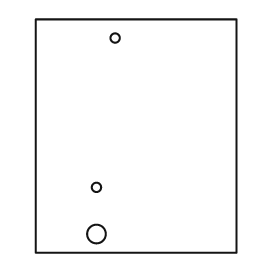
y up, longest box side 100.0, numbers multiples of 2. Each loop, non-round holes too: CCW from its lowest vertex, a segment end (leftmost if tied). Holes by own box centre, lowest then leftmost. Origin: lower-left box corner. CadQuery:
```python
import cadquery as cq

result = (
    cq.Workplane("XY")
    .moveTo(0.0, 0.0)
    .lineTo(86.0, 0.0)
    .lineTo(86.0, 100.0)
    .lineTo(0.0, 100.0)
    .close()
    .moveTo(26.0, 8.0)
    .circle(4.0)
    .moveTo(26.0, 28.0)
    .circle(2.0)
    .moveTo(34.0, 92.0)
    .circle(2.0)
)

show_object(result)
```